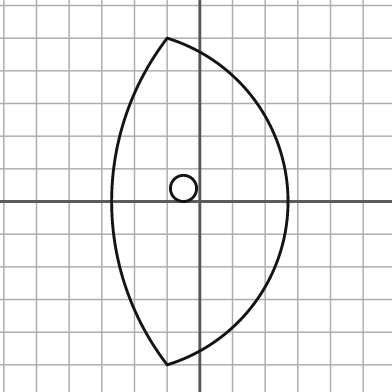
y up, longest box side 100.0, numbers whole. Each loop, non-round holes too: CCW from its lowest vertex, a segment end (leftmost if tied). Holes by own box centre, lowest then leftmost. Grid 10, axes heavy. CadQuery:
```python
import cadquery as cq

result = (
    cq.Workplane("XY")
    .moveTo(-10.0, -50.0)
    .threePointArc((27.0, 0.0), (-10.0, 50.0))
    .threePointArc((-27.0, 0.0), (-10.0, -50.0))
    .close()
    .moveTo(-5.0, 4.0)
    .circle(4.0)
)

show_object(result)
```